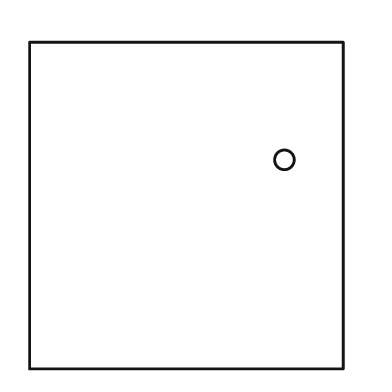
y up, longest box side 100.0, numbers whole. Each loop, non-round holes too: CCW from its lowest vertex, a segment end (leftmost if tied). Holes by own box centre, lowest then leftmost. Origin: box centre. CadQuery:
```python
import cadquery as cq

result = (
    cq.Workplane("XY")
    .moveTo(-48.0, -50.0)
    .lineTo(48.0, -50.0)
    .lineTo(48.0, 50.0)
    .lineTo(-48.0, 50.0)
    .close()
    .moveTo(30.0, 14.0)
    .circle(3.0)
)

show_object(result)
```